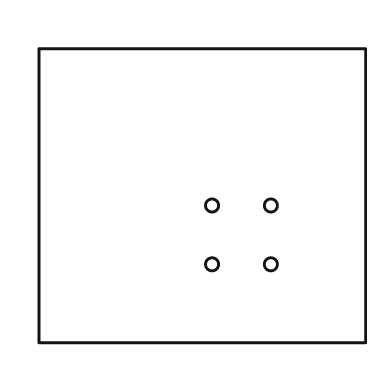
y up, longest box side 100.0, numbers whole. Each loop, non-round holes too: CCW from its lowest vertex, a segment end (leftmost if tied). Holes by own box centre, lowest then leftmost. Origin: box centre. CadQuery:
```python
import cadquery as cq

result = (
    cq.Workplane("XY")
    .moveTo(-50.0, -45.0)
    .lineTo(50.0, -45.0)
    .lineTo(50.0, 45.0)
    .lineTo(-50.0, 45.0)
    .close()
    .moveTo(3.0, -21.0)
    .circle(2.0)
    .moveTo(21.0, -21.0)
    .circle(2.0)
    .moveTo(3.0, -3.0)
    .circle(2.0)
    .moveTo(21.0, -3.0)
    .circle(2.0)
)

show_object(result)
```